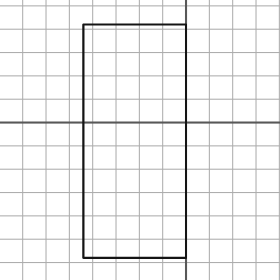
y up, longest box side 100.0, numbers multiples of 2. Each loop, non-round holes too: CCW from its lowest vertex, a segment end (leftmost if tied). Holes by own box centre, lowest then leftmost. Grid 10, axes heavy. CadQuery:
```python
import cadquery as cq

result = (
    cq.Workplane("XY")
    .moveTo(-44.0, -58.0)
    .lineTo(0.0, -58.0)
    .lineTo(0.0, 42.0)
    .lineTo(-44.0, 42.0)
    .close()
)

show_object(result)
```